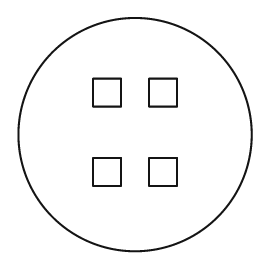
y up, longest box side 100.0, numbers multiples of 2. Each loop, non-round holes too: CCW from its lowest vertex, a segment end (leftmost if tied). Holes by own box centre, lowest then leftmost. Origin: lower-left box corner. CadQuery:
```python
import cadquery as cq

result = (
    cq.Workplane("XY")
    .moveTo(50.0, 50.0)
    .circle(50.0)
    .moveTo(32.0, 28.0)
    .lineTo(44.0, 28.0)
    .lineTo(44.0, 40.0)
    .lineTo(32.0, 40.0)
    .close()
    .moveTo(56.0, 28.0)
    .lineTo(68.0, 28.0)
    .lineTo(68.0, 40.0)
    .lineTo(56.0, 40.0)
    .close()
    .moveTo(32.0, 62.0)
    .lineTo(44.0, 62.0)
    .lineTo(44.0, 74.0)
    .lineTo(32.0, 74.0)
    .close()
    .moveTo(56.0, 62.0)
    .lineTo(68.0, 62.0)
    .lineTo(68.0, 74.0)
    .lineTo(56.0, 74.0)
    .close()
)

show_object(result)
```